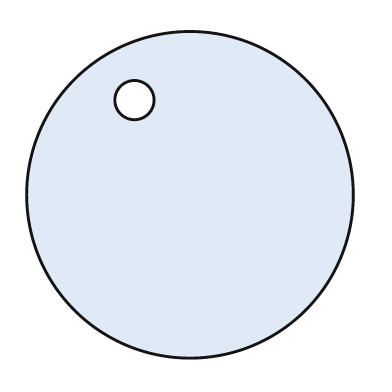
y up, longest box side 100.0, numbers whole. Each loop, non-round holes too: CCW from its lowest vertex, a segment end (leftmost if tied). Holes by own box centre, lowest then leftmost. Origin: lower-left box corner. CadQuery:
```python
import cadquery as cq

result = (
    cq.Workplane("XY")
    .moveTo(50.0, 50.0)
    .circle(50.0)
    .moveTo(33.0, 79.0)
    .circle(6.0)
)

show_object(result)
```